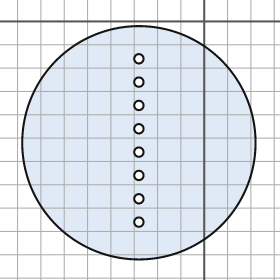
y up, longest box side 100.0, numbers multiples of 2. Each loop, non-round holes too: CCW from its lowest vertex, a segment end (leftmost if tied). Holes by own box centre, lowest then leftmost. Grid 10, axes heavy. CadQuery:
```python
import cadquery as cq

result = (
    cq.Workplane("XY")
    .moveTo(-28.0, -52.0)
    .circle(50.0)
    .moveTo(-28.0, -86.0)
    .circle(2.0)
    .moveTo(-28.0, -76.0)
    .circle(2.0)
    .moveTo(-28.0, -66.0)
    .circle(2.0)
    .moveTo(-28.0, -56.0)
    .circle(2.0)
    .moveTo(-28.0, -46.0)
    .circle(2.0)
    .moveTo(-28.0, -36.0)
    .circle(2.0)
    .moveTo(-28.0, -26.0)
    .circle(2.0)
    .moveTo(-28.0, -16.0)
    .circle(2.0)
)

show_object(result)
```